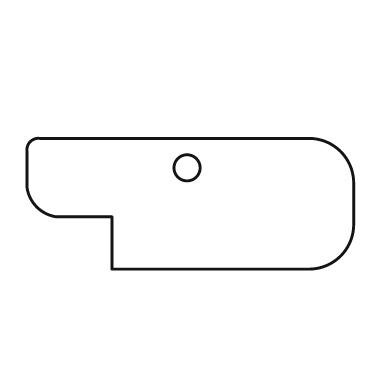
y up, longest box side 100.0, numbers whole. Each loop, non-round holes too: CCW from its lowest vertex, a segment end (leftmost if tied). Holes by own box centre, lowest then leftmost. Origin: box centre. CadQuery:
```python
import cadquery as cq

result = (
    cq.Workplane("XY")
    .moveTo(-24.0, -20.0)
    .lineTo(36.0, -20.0)
    .threePointArc((46.0, -16.0), (50.0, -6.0))
    .lineTo(50.0, 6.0)
    .threePointArc((46.0, 16.0), (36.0, 20.0))
    .lineTo(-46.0, 20.0)
    .threePointArc((-49.0, 19.0), (-50.0, 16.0))
    .lineTo(-50.0, 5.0)
    .threePointArc((-47.0, -1.0), (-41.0, -4.0))
    .lineTo(-24.0, -4.0)
    .close()
    .moveTo(-1.0, 11.0)
    .circle(4.0)
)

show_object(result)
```